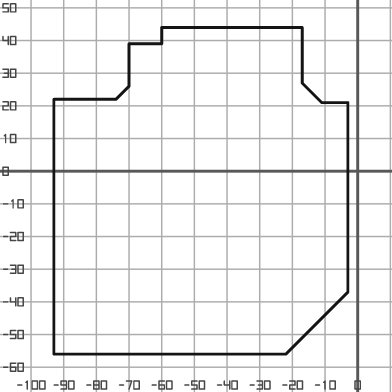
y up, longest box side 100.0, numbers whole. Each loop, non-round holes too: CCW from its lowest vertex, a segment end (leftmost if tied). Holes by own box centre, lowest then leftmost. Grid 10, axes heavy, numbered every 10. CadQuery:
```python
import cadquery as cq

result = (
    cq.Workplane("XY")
    .moveTo(-93.0, -56.0)
    .lineTo(-22.0, -56.0)
    .lineTo(-3.0, -37.0)
    .lineTo(-3.0, 21.0)
    .lineTo(-11.0, 21.0)
    .lineTo(-17.0, 27.0)
    .lineTo(-17.0, 44.0)
    .lineTo(-60.0, 44.0)
    .lineTo(-60.0, 39.0)
    .lineTo(-70.0, 39.0)
    .lineTo(-70.0, 26.0)
    .lineTo(-74.0, 22.0)
    .lineTo(-93.0, 22.0)
    .close()
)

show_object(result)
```